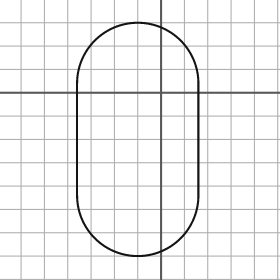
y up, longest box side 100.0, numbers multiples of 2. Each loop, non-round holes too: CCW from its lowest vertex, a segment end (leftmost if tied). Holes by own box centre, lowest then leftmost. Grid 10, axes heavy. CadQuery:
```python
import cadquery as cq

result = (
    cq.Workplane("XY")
    .moveTo(-36.0, -44.0)
    .threePointArc((-10.0, -70.0), (16.0, -44.0))
    .lineTo(16.0, 4.0)
    .threePointArc((-10.0, 30.0), (-36.0, 4.0))
    .close()
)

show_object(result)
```